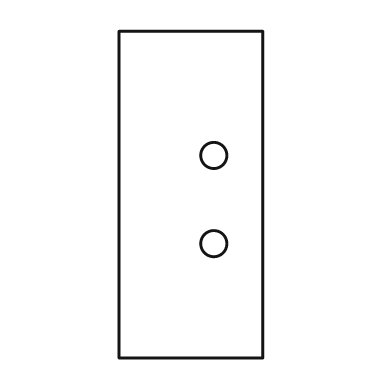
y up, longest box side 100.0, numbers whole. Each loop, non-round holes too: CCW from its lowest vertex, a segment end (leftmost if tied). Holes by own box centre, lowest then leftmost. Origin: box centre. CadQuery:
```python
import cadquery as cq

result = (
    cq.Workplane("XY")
    .moveTo(-22.0, -50.0)
    .lineTo(22.0, -50.0)
    .lineTo(22.0, 50.0)
    .lineTo(-22.0, 50.0)
    .close()
    .moveTo(7.0, -15.0)
    .circle(4.0)
    .moveTo(7.0, 12.0)
    .circle(4.0)
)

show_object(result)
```